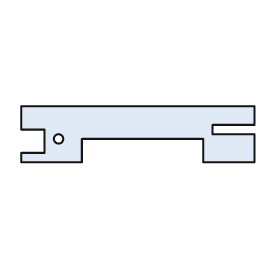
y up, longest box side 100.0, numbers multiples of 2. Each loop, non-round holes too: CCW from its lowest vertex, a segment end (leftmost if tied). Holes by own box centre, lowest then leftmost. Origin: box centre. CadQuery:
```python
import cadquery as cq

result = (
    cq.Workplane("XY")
    .moveTo(-50.0, -12.0)
    .lineTo(-24.0, -12.0)
    .lineTo(-24.0, -2.0)
    .lineTo(28.0, -2.0)
    .lineTo(28.0, -12.0)
    .lineTo(50.0, -12.0)
    .lineTo(50.0, 0.0)
    .lineTo(32.0, 0.0)
    .lineTo(32.0, 4.0)
    .lineTo(50.0, 4.0)
    .lineTo(50.0, 12.0)
    .lineTo(-50.0, 12.0)
    .lineTo(-50.0, 2.0)
    .lineTo(-40.0, 2.0)
    .lineTo(-40.0, -8.0)
    .lineTo(-50.0, -8.0)
    .close()
    .moveTo(-34.0, -2.0)
    .circle(2.0)
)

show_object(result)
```